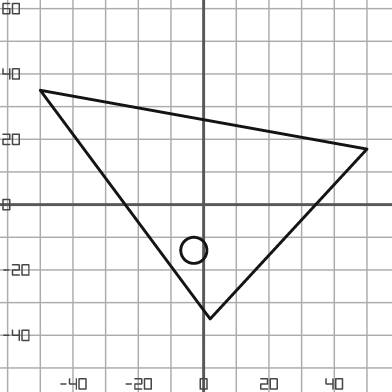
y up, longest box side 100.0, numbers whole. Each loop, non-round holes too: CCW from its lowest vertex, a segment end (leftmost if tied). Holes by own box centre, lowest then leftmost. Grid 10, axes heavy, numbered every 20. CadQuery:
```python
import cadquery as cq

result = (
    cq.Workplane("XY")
    .moveTo(2.0, -35.0)
    .lineTo(50.0, 17.0)
    .lineTo(-50.0, 35.0)
    .close()
    .moveTo(-3.0, -14.0)
    .circle(4.0)
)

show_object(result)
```